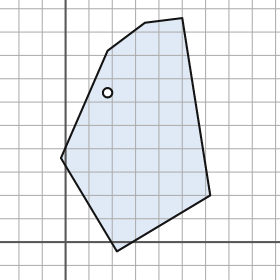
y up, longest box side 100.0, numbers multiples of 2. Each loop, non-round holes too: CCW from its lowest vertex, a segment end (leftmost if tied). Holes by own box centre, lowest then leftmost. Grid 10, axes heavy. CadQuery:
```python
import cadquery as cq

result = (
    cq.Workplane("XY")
    .moveTo(22.0, -4.0)
    .lineTo(62.0, 20.0)
    .lineTo(50.0, 96.0)
    .lineTo(34.0, 94.0)
    .lineTo(18.0, 82.0)
    .lineTo(-2.0, 36.0)
    .close()
    .moveTo(18.0, 64.0)
    .circle(2.0)
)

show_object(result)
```